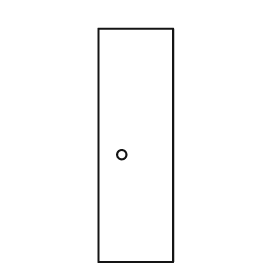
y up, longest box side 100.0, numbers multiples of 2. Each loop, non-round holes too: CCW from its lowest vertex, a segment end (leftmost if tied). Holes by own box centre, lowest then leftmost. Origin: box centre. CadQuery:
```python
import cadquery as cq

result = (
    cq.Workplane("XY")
    .moveTo(-16.0, -50.0)
    .lineTo(16.0, -50.0)
    .lineTo(16.0, 50.0)
    .lineTo(-16.0, 50.0)
    .close()
    .moveTo(-6.0, -4.0)
    .circle(2.0)
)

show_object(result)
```